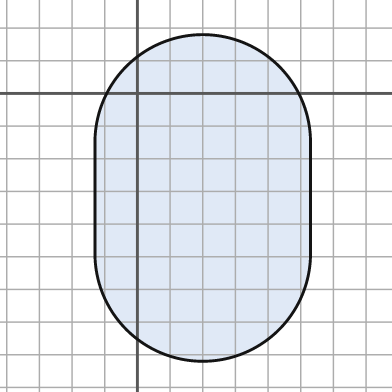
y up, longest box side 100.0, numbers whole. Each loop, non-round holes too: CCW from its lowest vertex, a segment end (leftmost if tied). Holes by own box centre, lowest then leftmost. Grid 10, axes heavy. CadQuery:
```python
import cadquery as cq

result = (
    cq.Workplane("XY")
    .moveTo(-13.0, -49.0)
    .threePointArc((20.0, -82.0), (53.0, -49.0))
    .lineTo(53.0, -15.0)
    .threePointArc((20.0, 18.0), (-13.0, -15.0))
    .close()
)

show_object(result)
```